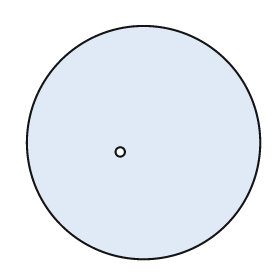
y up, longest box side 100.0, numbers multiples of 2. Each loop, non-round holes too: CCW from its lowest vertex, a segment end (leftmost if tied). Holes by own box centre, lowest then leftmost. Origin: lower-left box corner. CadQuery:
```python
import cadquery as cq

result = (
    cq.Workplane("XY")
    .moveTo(50.0, 50.0)
    .circle(50.0)
    .moveTo(40.0, 46.0)
    .circle(2.0)
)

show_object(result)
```